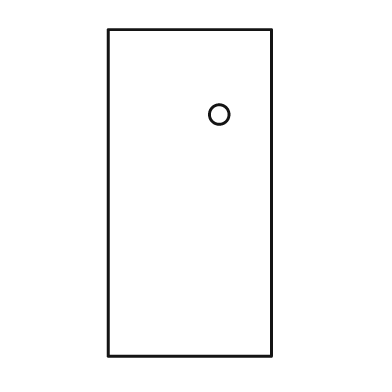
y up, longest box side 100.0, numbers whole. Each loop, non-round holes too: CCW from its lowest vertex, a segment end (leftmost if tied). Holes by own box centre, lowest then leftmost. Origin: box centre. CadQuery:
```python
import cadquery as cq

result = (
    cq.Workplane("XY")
    .moveTo(-25.0, -50.0)
    .lineTo(25.0, -50.0)
    .lineTo(25.0, 50.0)
    .lineTo(-25.0, 50.0)
    .close()
    .moveTo(9.0, 24.0)
    .circle(3.0)
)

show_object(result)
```